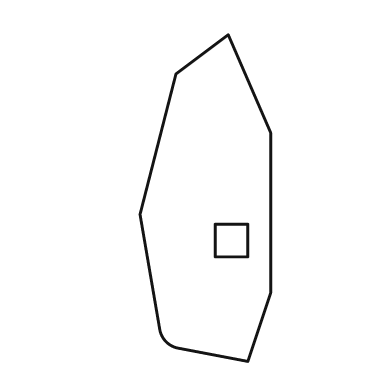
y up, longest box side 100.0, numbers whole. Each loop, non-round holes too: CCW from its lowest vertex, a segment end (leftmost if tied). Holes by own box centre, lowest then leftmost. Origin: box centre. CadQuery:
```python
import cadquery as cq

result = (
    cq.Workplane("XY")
    .moveTo(13.0, -50.0)
    .lineTo(20.0, -29.0)
    .lineTo(20.0, 20.0)
    .lineTo(7.0, 50.0)
    .lineTo(-9.0, 38.0)
    .lineTo(-20.0, -5.0)
    .lineTo(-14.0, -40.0)
    .threePointArc((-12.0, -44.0), (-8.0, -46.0))
    .close()
    .moveTo(3.0, -18.0)
    .lineTo(13.0, -18.0)
    .lineTo(13.0, -8.0)
    .lineTo(3.0, -8.0)
    .close()
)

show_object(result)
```